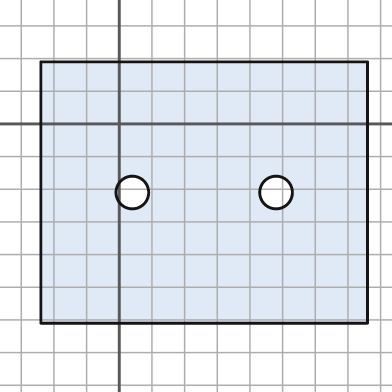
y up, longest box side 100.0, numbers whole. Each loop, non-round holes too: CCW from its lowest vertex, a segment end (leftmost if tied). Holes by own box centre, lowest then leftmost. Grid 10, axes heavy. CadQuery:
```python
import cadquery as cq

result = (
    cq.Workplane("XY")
    .moveTo(-24.0, -61.0)
    .lineTo(76.0, -61.0)
    .lineTo(76.0, 19.0)
    .lineTo(-24.0, 19.0)
    .close()
    .moveTo(4.0, -21.0)
    .circle(5.0)
    .moveTo(48.0, -21.0)
    .circle(5.0)
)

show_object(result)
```